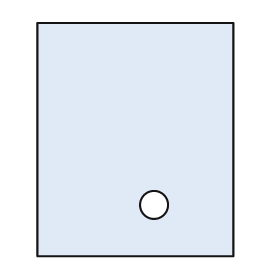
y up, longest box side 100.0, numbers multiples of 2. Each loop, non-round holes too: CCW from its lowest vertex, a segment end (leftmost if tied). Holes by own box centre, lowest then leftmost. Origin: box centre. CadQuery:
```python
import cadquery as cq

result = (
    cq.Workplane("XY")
    .moveTo(-42.0, -50.0)
    .lineTo(42.0, -50.0)
    .lineTo(42.0, 50.0)
    .lineTo(-42.0, 50.0)
    .close()
    .moveTo(8.0, -28.0)
    .circle(6.0)
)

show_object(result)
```